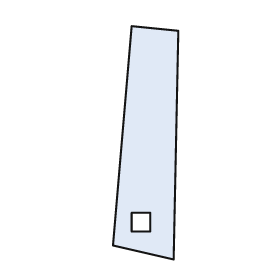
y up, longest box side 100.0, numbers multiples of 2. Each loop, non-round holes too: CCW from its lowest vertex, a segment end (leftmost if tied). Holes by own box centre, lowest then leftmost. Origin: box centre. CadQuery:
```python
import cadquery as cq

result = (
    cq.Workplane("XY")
    .moveTo(12.0, -50.0)
    .lineTo(14.0, 48.0)
    .lineTo(-6.0, 50.0)
    .lineTo(-14.0, -44.0)
    .close()
    .moveTo(-6.0, -38.0)
    .lineTo(2.0, -38.0)
    .lineTo(2.0, -30.0)
    .lineTo(-6.0, -30.0)
    .close()
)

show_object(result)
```